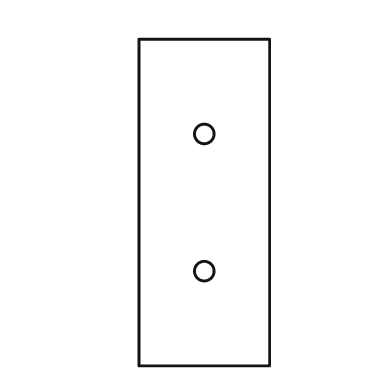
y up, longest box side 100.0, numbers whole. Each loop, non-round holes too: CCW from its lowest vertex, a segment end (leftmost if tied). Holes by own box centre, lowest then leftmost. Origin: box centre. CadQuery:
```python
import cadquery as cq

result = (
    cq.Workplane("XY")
    .moveTo(-20.0, -50.0)
    .lineTo(20.0, -50.0)
    .lineTo(20.0, 50.0)
    .lineTo(-20.0, 50.0)
    .close()
    .moveTo(0.0, -21.0)
    .circle(3.0)
    .moveTo(0.0, 21.0)
    .circle(3.0)
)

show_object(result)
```